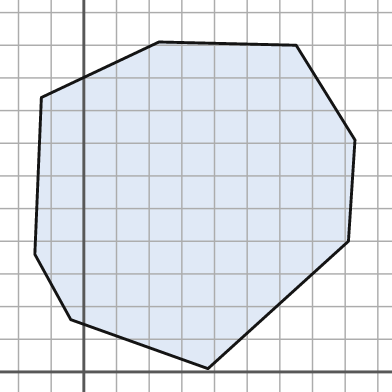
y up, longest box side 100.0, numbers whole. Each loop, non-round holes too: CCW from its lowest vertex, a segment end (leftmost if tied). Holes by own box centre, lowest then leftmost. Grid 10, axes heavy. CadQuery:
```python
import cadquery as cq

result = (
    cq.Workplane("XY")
    .moveTo(38.0, 1.0)
    .lineTo(81.0, 40.0)
    .lineTo(83.0, 71.0)
    .lineTo(65.0, 100.0)
    .lineTo(23.0, 101.0)
    .lineTo(-13.0, 84.0)
    .lineTo(-15.0, 36.0)
    .lineTo(-4.0, 16.0)
    .close()
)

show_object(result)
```